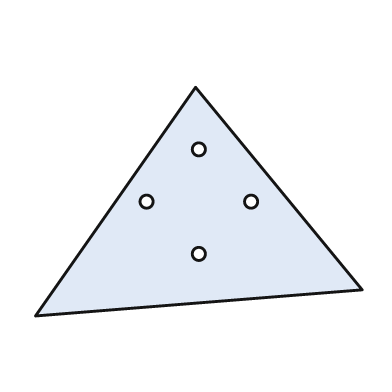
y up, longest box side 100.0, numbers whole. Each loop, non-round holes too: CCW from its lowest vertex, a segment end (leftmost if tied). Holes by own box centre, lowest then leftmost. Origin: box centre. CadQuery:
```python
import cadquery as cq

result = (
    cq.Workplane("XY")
    .moveTo(-50.0, -35.0)
    .lineTo(50.0, -27.0)
    .lineTo(-1.0, 35.0)
    .close()
    .moveTo(0.0, -16.0)
    .circle(2.0)
    .moveTo(-16.0, 0.0)
    .circle(2.0)
    .moveTo(16.0, 0.0)
    .circle(2.0)
    .moveTo(0.0, 16.0)
    .circle(2.0)
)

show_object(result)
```